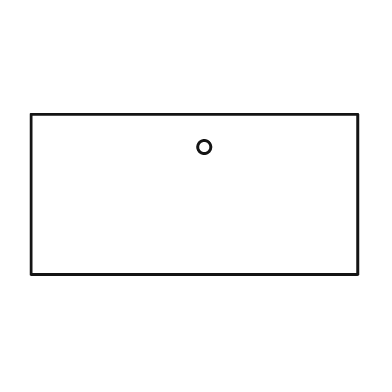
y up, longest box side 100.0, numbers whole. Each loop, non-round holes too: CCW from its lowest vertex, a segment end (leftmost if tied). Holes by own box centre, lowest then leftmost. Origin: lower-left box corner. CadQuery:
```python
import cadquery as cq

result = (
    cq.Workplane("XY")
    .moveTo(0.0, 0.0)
    .lineTo(100.0, 0.0)
    .lineTo(100.0, 49.0)
    .lineTo(0.0, 49.0)
    .close()
    .moveTo(53.0, 39.0)
    .circle(2.0)
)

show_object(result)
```